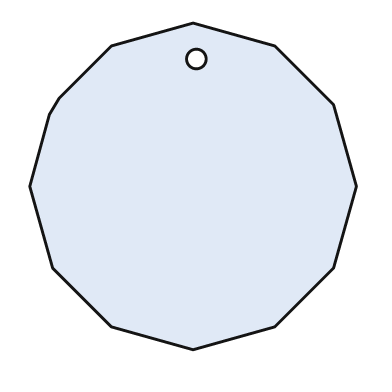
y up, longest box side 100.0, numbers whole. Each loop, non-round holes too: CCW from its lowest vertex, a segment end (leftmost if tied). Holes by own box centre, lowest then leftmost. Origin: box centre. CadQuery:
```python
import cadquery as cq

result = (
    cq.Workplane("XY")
    .moveTo(0.0, -50.0)
    .lineTo(25.0, -43.0)
    .lineTo(43.0, -25.0)
    .lineTo(50.0, 0.0)
    .lineTo(43.0, 25.0)
    .lineTo(25.0, 43.0)
    .lineTo(0.0, 50.0)
    .lineTo(-25.0, 43.0)
    .lineTo(-41.0, 27.0)
    .lineTo(-44.0, 22.0)
    .lineTo(-50.0, 0.0)
    .lineTo(-43.0, -25.0)
    .lineTo(-25.0, -43.0)
    .close()
    .moveTo(1.0, 39.0)
    .circle(3.0)
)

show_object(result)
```